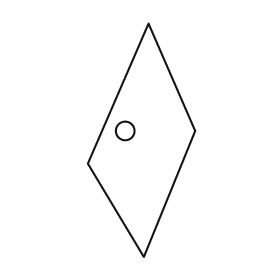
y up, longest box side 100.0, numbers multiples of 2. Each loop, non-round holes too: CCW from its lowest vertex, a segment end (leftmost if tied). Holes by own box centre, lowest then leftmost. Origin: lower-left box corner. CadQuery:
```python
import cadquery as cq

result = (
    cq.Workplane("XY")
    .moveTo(24.0, 0.0)
    .lineTo(46.0, 54.0)
    .lineTo(26.0, 100.0)
    .lineTo(0.0, 40.0)
    .close()
    .moveTo(16.0, 54.0)
    .circle(4.0)
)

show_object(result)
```